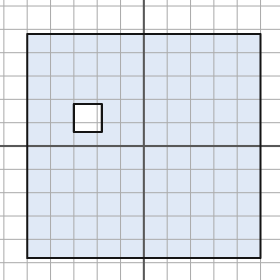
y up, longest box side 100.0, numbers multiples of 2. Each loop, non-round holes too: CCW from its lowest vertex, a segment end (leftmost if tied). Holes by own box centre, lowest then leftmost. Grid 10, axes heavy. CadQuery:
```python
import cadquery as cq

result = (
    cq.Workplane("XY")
    .moveTo(-50.0, -48.0)
    .lineTo(50.0, -48.0)
    .lineTo(50.0, 48.0)
    .lineTo(-50.0, 48.0)
    .close()
    .moveTo(-30.0, 6.0)
    .lineTo(-18.0, 6.0)
    .lineTo(-18.0, 18.0)
    .lineTo(-30.0, 18.0)
    .close()
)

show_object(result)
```